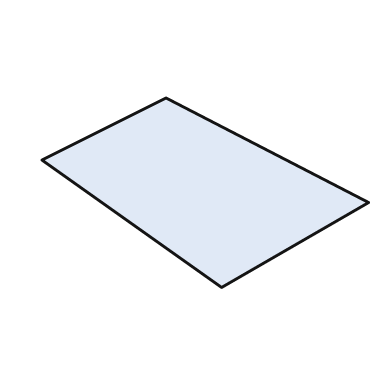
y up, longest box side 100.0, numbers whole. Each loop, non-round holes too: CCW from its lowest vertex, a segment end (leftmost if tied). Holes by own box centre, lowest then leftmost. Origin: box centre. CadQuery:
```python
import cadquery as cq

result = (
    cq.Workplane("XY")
    .moveTo(5.0, -29.0)
    .lineTo(50.0, -3.0)
    .lineTo(-12.0, 29.0)
    .lineTo(-50.0, 10.0)
    .close()
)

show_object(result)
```